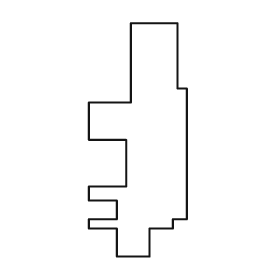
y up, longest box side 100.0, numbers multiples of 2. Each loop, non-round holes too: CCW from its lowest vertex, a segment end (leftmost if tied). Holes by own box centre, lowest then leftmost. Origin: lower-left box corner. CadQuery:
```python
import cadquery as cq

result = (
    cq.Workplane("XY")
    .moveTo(12.0, 0.0)
    .lineTo(26.0, 0.0)
    .lineTo(26.0, 12.0)
    .lineTo(36.0, 12.0)
    .lineTo(36.0, 16.0)
    .lineTo(42.0, 16.0)
    .lineTo(42.0, 72.0)
    .lineTo(38.0, 72.0)
    .lineTo(38.0, 100.0)
    .lineTo(18.0, 100.0)
    .lineTo(18.0, 66.0)
    .lineTo(0.0, 66.0)
    .lineTo(0.0, 50.0)
    .lineTo(16.0, 50.0)
    .lineTo(16.0, 30.0)
    .lineTo(0.0, 30.0)
    .lineTo(0.0, 24.0)
    .lineTo(12.0, 24.0)
    .lineTo(12.0, 16.0)
    .lineTo(0.0, 16.0)
    .lineTo(0.0, 12.0)
    .lineTo(12.0, 12.0)
    .close()
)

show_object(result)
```